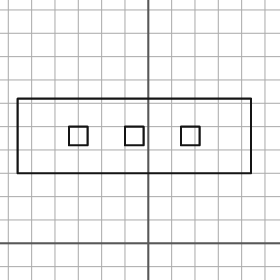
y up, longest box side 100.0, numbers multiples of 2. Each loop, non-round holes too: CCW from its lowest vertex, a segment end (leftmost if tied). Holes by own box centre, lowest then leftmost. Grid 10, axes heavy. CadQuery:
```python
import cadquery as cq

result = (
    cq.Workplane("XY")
    .moveTo(-56.0, 30.0)
    .lineTo(44.0, 30.0)
    .lineTo(44.0, 62.0)
    .lineTo(-56.0, 62.0)
    .close()
    .moveTo(-34.0, 42.0)
    .lineTo(-26.0, 42.0)
    .lineTo(-26.0, 50.0)
    .lineTo(-34.0, 50.0)
    .close()
    .moveTo(-10.0, 42.0)
    .lineTo(-2.0, 42.0)
    .lineTo(-2.0, 50.0)
    .lineTo(-10.0, 50.0)
    .close()
    .moveTo(14.0, 42.0)
    .lineTo(22.0, 42.0)
    .lineTo(22.0, 50.0)
    .lineTo(14.0, 50.0)
    .close()
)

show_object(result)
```